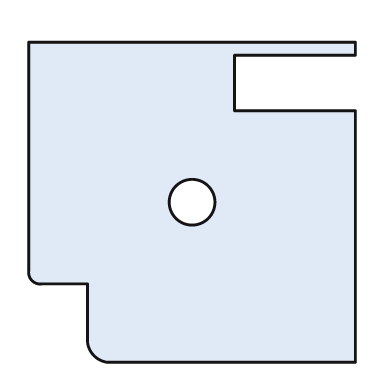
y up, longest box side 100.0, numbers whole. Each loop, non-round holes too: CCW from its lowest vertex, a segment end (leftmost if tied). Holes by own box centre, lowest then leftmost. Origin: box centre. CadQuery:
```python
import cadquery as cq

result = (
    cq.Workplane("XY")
    .moveTo(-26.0, -49.0)
    .lineTo(50.0, -49.0)
    .lineTo(50.0, 28.0)
    .lineTo(13.0, 28.0)
    .lineTo(13.0, 45.0)
    .lineTo(50.0, 45.0)
    .lineTo(50.0, 49.0)
    .lineTo(-50.0, 49.0)
    .lineTo(-50.0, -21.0)
    .threePointArc((-49.0, -24.0), (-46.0, -25.0))
    .lineTo(-32.0, -25.0)
    .lineTo(-32.0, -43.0)
    .threePointArc((-30.0, -47.0), (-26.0, -49.0))
    .close()
    .moveTo(0.0, 0.0)
    .circle(7.0)
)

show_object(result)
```